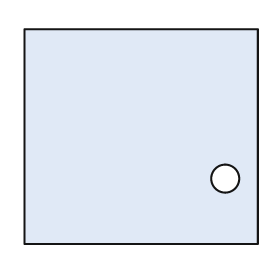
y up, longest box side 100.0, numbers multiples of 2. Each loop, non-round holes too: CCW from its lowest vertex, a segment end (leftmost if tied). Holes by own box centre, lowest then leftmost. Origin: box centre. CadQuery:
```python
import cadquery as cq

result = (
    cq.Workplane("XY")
    .moveTo(-50.0, -46.0)
    .lineTo(50.0, -46.0)
    .lineTo(50.0, 46.0)
    .lineTo(-50.0, 46.0)
    .close()
    .moveTo(36.0, -18.0)
    .circle(6.0)
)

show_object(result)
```